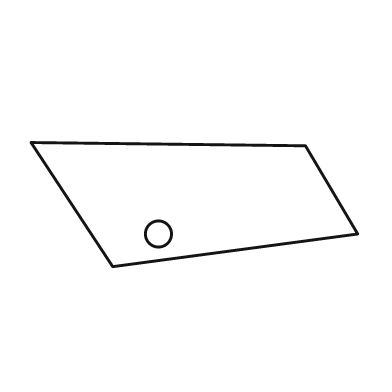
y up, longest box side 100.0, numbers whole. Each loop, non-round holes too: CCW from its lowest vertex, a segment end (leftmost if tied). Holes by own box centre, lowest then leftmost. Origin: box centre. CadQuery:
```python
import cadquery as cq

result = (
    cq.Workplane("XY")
    .moveTo(-25.0, -19.0)
    .lineTo(50.0, -9.0)
    .lineTo(34.0, 18.0)
    .lineTo(-50.0, 19.0)
    .close()
    .moveTo(-11.0, -9.0)
    .circle(4.0)
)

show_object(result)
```